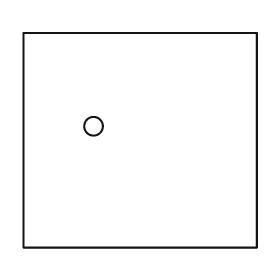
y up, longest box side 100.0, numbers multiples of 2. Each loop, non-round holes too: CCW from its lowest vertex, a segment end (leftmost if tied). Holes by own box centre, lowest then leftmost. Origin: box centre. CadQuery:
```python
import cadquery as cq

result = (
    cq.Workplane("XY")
    .moveTo(-50.0, -46.0)
    .lineTo(50.0, -46.0)
    .lineTo(50.0, 46.0)
    .lineTo(-50.0, 46.0)
    .close()
    .moveTo(-20.0, 6.0)
    .circle(4.0)
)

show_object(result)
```